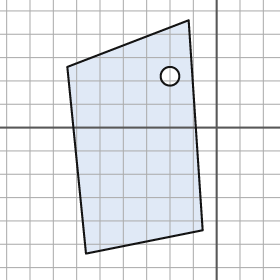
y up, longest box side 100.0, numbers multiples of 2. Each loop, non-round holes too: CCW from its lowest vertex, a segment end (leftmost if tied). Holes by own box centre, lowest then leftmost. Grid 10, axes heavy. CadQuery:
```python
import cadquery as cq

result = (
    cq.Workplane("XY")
    .moveTo(-56.0, -54.0)
    .lineTo(-6.0, -44.0)
    .lineTo(-12.0, 46.0)
    .lineTo(-64.0, 26.0)
    .close()
    .moveTo(-20.0, 22.0)
    .circle(4.0)
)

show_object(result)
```